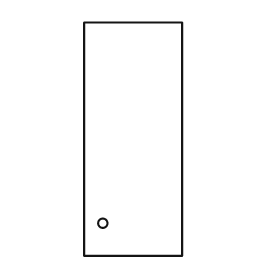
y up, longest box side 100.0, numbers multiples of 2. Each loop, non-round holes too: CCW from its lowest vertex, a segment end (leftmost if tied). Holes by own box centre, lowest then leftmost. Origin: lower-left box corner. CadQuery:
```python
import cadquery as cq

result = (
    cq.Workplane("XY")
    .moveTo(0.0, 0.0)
    .lineTo(42.0, 0.0)
    .lineTo(42.0, 100.0)
    .lineTo(0.0, 100.0)
    .close()
    .moveTo(8.0, 14.0)
    .circle(2.0)
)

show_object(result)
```